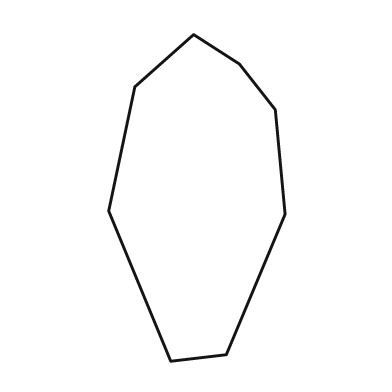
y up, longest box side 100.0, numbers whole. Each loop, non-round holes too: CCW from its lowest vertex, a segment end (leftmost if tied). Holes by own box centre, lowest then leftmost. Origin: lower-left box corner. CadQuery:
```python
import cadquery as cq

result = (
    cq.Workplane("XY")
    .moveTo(19.0, 0.0)
    .lineTo(36.0, 2.0)
    .lineTo(54.0, 45.0)
    .lineTo(51.0, 77.0)
    .lineTo(40.0, 91.0)
    .lineTo(26.0, 100.0)
    .lineTo(8.0, 84.0)
    .lineTo(0.0, 46.0)
    .close()
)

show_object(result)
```